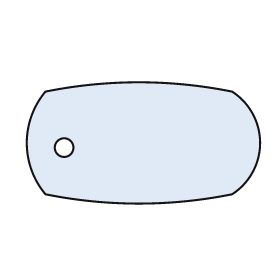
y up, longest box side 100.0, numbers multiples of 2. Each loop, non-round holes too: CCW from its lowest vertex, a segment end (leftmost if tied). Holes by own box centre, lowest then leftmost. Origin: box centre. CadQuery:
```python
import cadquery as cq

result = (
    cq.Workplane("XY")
    .moveTo(-42.0, -22.0)
    .threePointArc((-2.0, -26.0), (38.0, -22.0))
    .threePointArc((50.0, 0.0), (38.0, 22.0))
    .threePointArc((-2.0, 26.0), (-42.0, 22.0))
    .threePointArc((-50.0, 0.0), (-42.0, -22.0))
    .close()
    .moveTo(-34.0, -2.0)
    .circle(4.0)
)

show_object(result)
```